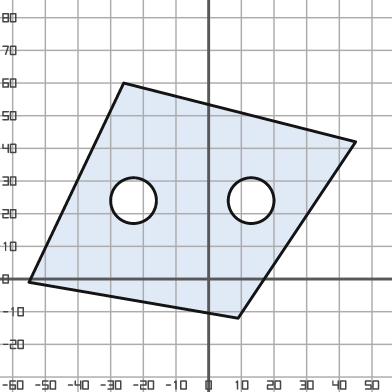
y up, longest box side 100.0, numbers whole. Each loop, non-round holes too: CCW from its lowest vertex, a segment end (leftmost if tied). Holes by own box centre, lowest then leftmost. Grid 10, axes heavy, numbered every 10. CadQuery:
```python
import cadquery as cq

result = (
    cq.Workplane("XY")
    .moveTo(9.0, -12.0)
    .lineTo(45.0, 42.0)
    .lineTo(-26.0, 60.0)
    .lineTo(-55.0, -1.0)
    .close()
    .moveTo(-23.0, 24.0)
    .circle(7.0)
    .moveTo(13.0, 24.0)
    .circle(7.0)
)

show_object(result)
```